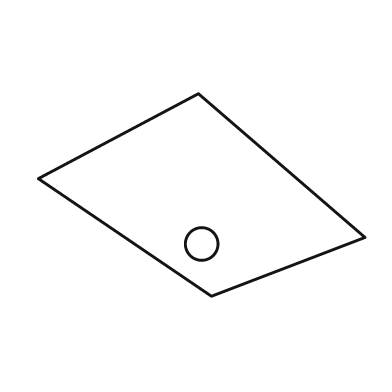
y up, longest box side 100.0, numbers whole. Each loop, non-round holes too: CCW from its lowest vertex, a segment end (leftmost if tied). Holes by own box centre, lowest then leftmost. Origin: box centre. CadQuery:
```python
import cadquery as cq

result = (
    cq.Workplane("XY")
    .moveTo(3.0, -31.0)
    .lineTo(50.0, -13.0)
    .lineTo(-1.0, 31.0)
    .lineTo(-50.0, 5.0)
    .close()
    .moveTo(0.0, -15.0)
    .circle(5.0)
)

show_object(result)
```